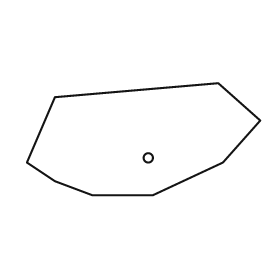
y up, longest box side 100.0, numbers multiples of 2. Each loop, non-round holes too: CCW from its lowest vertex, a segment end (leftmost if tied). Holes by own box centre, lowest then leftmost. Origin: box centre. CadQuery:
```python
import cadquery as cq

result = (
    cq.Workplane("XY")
    .moveTo(-22.0, -24.0)
    .lineTo(4.0, -24.0)
    .lineTo(34.0, -10.0)
    .lineTo(50.0, 8.0)
    .lineTo(32.0, 24.0)
    .lineTo(-38.0, 18.0)
    .lineTo(-50.0, -10.0)
    .lineTo(-38.0, -18.0)
    .close()
    .moveTo(2.0, -8.0)
    .circle(2.0)
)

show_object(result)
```